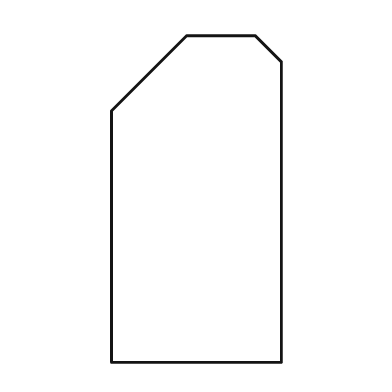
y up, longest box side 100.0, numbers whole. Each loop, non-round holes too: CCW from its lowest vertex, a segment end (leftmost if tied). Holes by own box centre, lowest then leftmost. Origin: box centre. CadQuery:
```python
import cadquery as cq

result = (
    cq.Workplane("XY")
    .moveTo(-26.0, -50.0)
    .lineTo(26.0, -50.0)
    .lineTo(26.0, 42.0)
    .lineTo(18.0, 50.0)
    .lineTo(-3.0, 50.0)
    .lineTo(-26.0, 27.0)
    .close()
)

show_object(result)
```